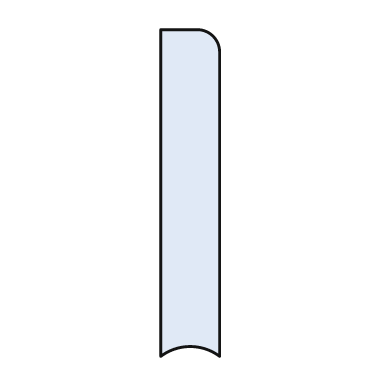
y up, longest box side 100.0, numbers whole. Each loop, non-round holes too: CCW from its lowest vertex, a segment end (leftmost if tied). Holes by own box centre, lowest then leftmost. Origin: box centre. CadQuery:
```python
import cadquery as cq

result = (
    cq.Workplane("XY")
    .moveTo(-9.0, -50.0)
    .threePointArc((0.0, -47.0), (9.0, -50.0))
    .lineTo(9.0, 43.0)
    .threePointArc((7.0, 48.0), (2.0, 50.0))
    .lineTo(-9.0, 50.0)
    .close()
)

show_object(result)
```